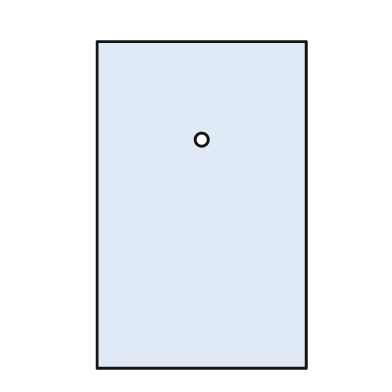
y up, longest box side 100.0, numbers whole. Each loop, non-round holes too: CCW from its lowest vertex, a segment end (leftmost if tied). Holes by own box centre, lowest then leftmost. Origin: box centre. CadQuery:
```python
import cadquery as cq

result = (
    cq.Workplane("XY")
    .moveTo(-32.0, -50.0)
    .lineTo(32.0, -50.0)
    .lineTo(32.0, 50.0)
    .lineTo(-32.0, 50.0)
    .close()
    .moveTo(0.0, 20.0)
    .circle(2.0)
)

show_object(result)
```